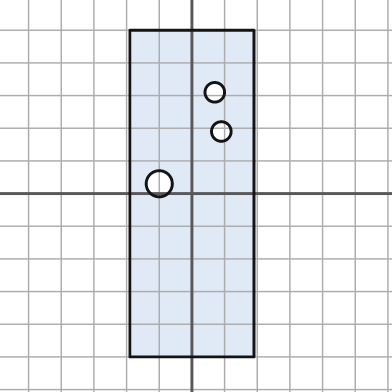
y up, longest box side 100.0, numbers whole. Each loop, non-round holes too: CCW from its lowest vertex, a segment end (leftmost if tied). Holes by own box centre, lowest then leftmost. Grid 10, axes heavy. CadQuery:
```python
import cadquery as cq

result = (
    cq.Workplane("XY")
    .moveTo(-19.0, -50.0)
    .lineTo(19.0, -50.0)
    .lineTo(19.0, 50.0)
    .lineTo(-19.0, 50.0)
    .close()
    .moveTo(-10.0, 3.0)
    .circle(4.0)
    .moveTo(9.0, 19.0)
    .circle(3.0)
    .moveTo(7.0, 31.0)
    .circle(3.0)
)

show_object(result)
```